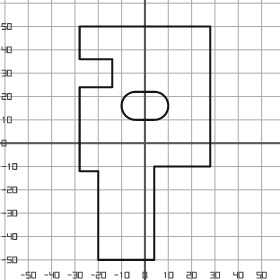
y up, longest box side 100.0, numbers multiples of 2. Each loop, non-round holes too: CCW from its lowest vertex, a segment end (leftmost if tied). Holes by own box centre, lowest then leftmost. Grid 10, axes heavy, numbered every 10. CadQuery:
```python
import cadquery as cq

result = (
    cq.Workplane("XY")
    .moveTo(-20.0, -50.0)
    .lineTo(4.0, -50.0)
    .lineTo(4.0, -10.0)
    .lineTo(28.0, -10.0)
    .lineTo(28.0, 50.0)
    .lineTo(-28.0, 50.0)
    .lineTo(-28.0, 36.0)
    .lineTo(-14.0, 36.0)
    .lineTo(-14.0, 24.0)
    .lineTo(-28.0, 24.0)
    .lineTo(-28.0, -12.0)
    .lineTo(-20.0, -12.0)
    .close()
    .moveTo(-4.0, 10.0)
    .lineTo(4.0, 10.0)
    .threePointArc((10.0, 16.0), (4.0, 22.0))
    .lineTo(-4.0, 22.0)
    .threePointArc((-10.0, 16.0), (-4.0, 10.0))
    .close()
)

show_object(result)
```